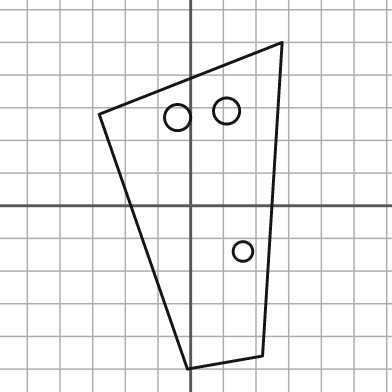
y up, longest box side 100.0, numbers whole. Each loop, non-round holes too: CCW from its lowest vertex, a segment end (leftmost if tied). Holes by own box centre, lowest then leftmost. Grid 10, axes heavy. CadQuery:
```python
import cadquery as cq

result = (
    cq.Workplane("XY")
    .moveTo(-1.0, -50.0)
    .lineTo(22.0, -46.0)
    .lineTo(28.0, 50.0)
    .lineTo(-28.0, 28.0)
    .close()
    .moveTo(16.0, -14.0)
    .circle(3.0)
    .moveTo(-4.0, 27.0)
    .circle(4.0)
    .moveTo(11.0, 29.0)
    .circle(4.0)
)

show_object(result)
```